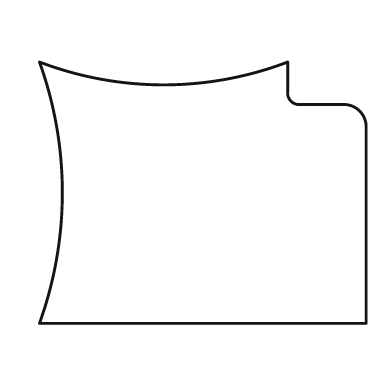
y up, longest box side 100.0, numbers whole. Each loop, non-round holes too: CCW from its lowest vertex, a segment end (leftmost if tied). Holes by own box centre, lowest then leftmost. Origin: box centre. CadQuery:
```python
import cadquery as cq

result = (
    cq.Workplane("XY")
    .moveTo(-50.0, -40.0)
    .lineTo(50.0, -40.0)
    .lineTo(50.0, 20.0)
    .threePointArc((48.0, 25.0), (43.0, 27.0))
    .lineTo(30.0, 27.0)
    .threePointArc((27.0, 28.0), (26.0, 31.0))
    .lineTo(26.0, 40.0)
    .threePointArc((-12.0, 33.0), (-50.0, 40.0))
    .threePointArc((-43.0, 0.0), (-50.0, -40.0))
    .close()
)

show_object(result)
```